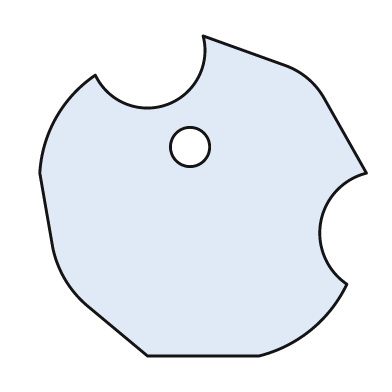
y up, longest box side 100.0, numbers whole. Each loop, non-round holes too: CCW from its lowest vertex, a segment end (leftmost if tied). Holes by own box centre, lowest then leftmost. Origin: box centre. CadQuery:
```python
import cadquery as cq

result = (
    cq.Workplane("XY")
    .moveTo(-17.0, -49.0)
    .lineTo(17.0, -49.0)
    .threePointArc((33.0, -41.0), (44.0, -27.0))
    .threePointArc((36.0, -8.0), (50.0, 7.0))
    .lineTo(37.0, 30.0)
    .threePointArc((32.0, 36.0), (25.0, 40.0))
    .lineTo(0.0, 49.0)
    .threePointArc((-11.0, 28.0), (-33.0, 37.0))
    .threePointArc((-45.0, 24.0), (-50.0, 7.0))
    .lineTo(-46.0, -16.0)
    .threePointArc((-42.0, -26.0), (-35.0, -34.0))
    .close()
    .moveTo(-4.0, 15.0)
    .circle(6.0)
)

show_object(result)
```